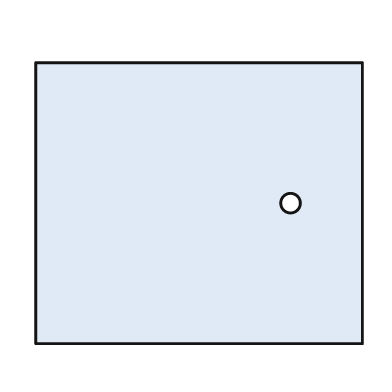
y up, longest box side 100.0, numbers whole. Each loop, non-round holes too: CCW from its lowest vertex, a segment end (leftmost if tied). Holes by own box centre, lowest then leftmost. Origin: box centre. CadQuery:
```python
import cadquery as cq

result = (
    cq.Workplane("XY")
    .moveTo(-50.0, -43.0)
    .lineTo(50.0, -43.0)
    .lineTo(50.0, 43.0)
    .lineTo(-50.0, 43.0)
    .close()
    .moveTo(28.0, 0.0)
    .circle(3.0)
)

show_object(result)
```